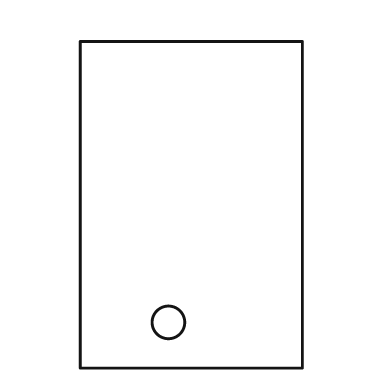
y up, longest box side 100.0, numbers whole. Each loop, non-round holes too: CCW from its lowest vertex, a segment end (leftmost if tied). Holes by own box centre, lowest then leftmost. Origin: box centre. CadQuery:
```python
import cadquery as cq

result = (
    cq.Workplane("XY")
    .moveTo(-34.0, -50.0)
    .lineTo(34.0, -50.0)
    .lineTo(34.0, 50.0)
    .lineTo(-34.0, 50.0)
    .close()
    .moveTo(-7.0, -36.0)
    .circle(5.0)
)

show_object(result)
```